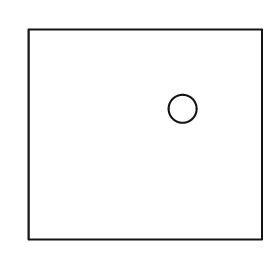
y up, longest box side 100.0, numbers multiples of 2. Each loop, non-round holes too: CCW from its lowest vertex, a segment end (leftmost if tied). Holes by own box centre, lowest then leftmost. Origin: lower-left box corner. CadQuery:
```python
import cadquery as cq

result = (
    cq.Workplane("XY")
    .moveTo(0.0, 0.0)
    .lineTo(100.0, 0.0)
    .lineTo(100.0, 90.0)
    .lineTo(0.0, 90.0)
    .close()
    .moveTo(66.0, 56.0)
    .circle(6.0)
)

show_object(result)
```